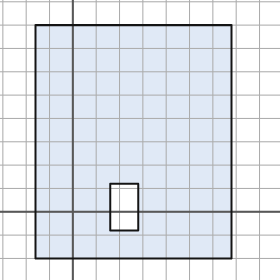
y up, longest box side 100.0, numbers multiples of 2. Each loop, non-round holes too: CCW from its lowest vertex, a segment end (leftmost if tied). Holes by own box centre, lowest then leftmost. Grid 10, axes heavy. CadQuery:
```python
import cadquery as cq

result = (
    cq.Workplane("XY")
    .moveTo(-16.0, -20.0)
    .lineTo(68.0, -20.0)
    .lineTo(68.0, 80.0)
    .lineTo(-16.0, 80.0)
    .close()
    .moveTo(16.0, -8.0)
    .lineTo(28.0, -8.0)
    .lineTo(28.0, 12.0)
    .lineTo(16.0, 12.0)
    .close()
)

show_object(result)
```